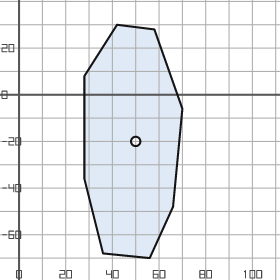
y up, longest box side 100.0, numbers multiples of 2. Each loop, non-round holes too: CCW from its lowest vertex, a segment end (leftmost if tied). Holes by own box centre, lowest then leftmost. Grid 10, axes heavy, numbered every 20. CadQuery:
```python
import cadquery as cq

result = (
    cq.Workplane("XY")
    .moveTo(56.0, -70.0)
    .lineTo(66.0, -48.0)
    .lineTo(70.0, -6.0)
    .lineTo(58.0, 28.0)
    .lineTo(42.0, 30.0)
    .lineTo(28.0, 8.0)
    .lineTo(28.0, -36.0)
    .lineTo(36.0, -68.0)
    .close()
    .moveTo(50.0, -20.0)
    .circle(2.0)
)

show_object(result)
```